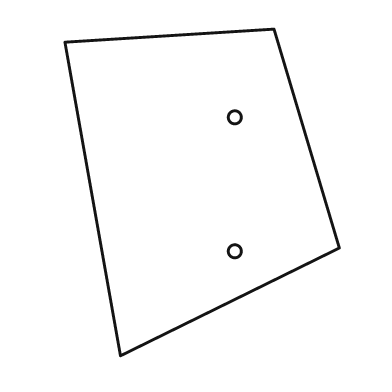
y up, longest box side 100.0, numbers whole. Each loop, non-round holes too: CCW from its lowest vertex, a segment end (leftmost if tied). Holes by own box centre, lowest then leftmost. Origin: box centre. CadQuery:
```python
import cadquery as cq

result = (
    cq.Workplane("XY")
    .moveTo(-25.0, -50.0)
    .lineTo(42.0, -17.0)
    .lineTo(22.0, 50.0)
    .lineTo(-42.0, 46.0)
    .close()
    .moveTo(10.0, -18.0)
    .circle(2.0)
    .moveTo(10.0, 23.0)
    .circle(2.0)
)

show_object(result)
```